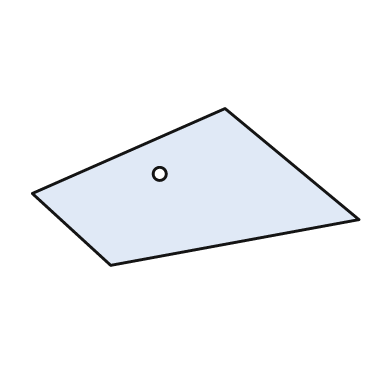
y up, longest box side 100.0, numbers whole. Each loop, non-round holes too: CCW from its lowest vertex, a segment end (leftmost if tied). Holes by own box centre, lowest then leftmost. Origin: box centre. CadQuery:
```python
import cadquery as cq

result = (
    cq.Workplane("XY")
    .moveTo(-26.0, -24.0)
    .lineTo(50.0, -10.0)
    .lineTo(9.0, 24.0)
    .lineTo(-50.0, -2.0)
    .close()
    .moveTo(-11.0, 4.0)
    .circle(2.0)
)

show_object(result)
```